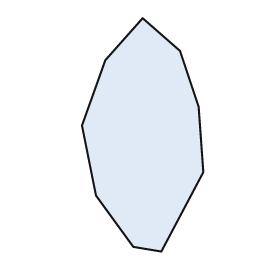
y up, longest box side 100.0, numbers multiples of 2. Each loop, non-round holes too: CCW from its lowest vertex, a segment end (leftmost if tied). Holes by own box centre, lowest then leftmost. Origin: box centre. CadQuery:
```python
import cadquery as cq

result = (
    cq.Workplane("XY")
    .moveTo(8.0, -50.0)
    .lineTo(26.0, -16.0)
    .lineTo(24.0, 12.0)
    .lineTo(16.0, 36.0)
    .lineTo(0.0, 50.0)
    .lineTo(-16.0, 32.0)
    .lineTo(-26.0, 4.0)
    .lineTo(-20.0, -26.0)
    .lineTo(-4.0, -48.0)
    .close()
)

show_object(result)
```